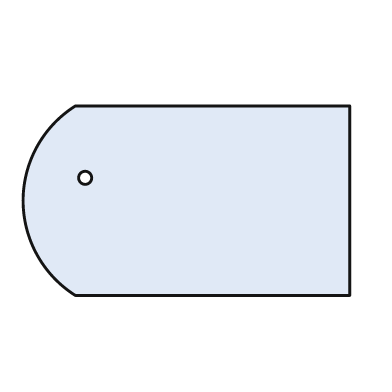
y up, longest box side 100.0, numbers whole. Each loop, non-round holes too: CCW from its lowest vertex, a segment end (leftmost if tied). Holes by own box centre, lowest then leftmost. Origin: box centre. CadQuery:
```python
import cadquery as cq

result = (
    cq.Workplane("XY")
    .moveTo(-34.0, -29.0)
    .lineTo(50.0, -29.0)
    .lineTo(50.0, 29.0)
    .lineTo(-34.0, 29.0)
    .threePointArc((-50.0, 0.0), (-34.0, -29.0))
    .close()
    .moveTo(-31.0, 7.0)
    .circle(2.0)
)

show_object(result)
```